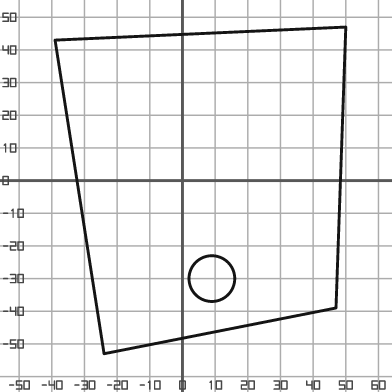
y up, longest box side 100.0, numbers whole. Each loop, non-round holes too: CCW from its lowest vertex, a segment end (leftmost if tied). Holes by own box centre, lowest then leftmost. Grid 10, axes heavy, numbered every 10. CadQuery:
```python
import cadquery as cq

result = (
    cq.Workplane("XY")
    .moveTo(-24.0, -53.0)
    .lineTo(47.0, -39.0)
    .lineTo(50.0, 47.0)
    .lineTo(-39.0, 43.0)
    .close()
    .moveTo(9.0, -30.0)
    .circle(7.0)
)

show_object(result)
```